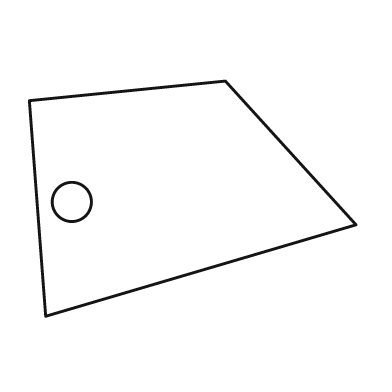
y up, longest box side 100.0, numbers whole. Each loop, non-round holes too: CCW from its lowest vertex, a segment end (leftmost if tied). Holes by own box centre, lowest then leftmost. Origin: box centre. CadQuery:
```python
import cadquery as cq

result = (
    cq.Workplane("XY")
    .moveTo(-45.0, -36.0)
    .lineTo(50.0, -8.0)
    .lineTo(10.0, 36.0)
    .lineTo(-50.0, 30.0)
    .close()
    .moveTo(-37.0, -1.0)
    .circle(6.0)
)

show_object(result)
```